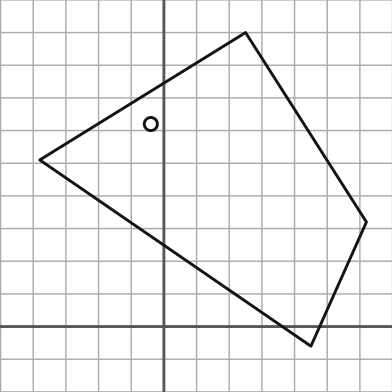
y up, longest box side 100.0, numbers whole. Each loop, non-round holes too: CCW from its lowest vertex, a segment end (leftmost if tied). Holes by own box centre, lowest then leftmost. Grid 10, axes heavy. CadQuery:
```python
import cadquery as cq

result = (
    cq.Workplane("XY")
    .moveTo(45.0, -6.0)
    .lineTo(62.0, 32.0)
    .lineTo(25.0, 90.0)
    .lineTo(-38.0, 51.0)
    .close()
    .moveTo(-4.0, 62.0)
    .circle(2.0)
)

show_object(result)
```